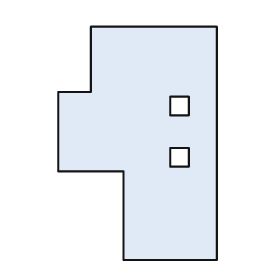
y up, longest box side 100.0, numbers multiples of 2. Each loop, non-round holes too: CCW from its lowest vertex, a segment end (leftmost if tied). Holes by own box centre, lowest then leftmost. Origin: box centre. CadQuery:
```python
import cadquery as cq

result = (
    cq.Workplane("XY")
    .moveTo(-6.0, -50.0)
    .lineTo(34.0, -50.0)
    .lineTo(34.0, 50.0)
    .lineTo(-20.0, 50.0)
    .lineTo(-20.0, 22.0)
    .lineTo(-34.0, 22.0)
    .lineTo(-34.0, -12.0)
    .lineTo(-6.0, -12.0)
    .close()
    .moveTo(14.0, -10.0)
    .lineTo(22.0, -10.0)
    .lineTo(22.0, -2.0)
    .lineTo(14.0, -2.0)
    .close()
    .moveTo(14.0, 12.0)
    .lineTo(22.0, 12.0)
    .lineTo(22.0, 20.0)
    .lineTo(14.0, 20.0)
    .close()
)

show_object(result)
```